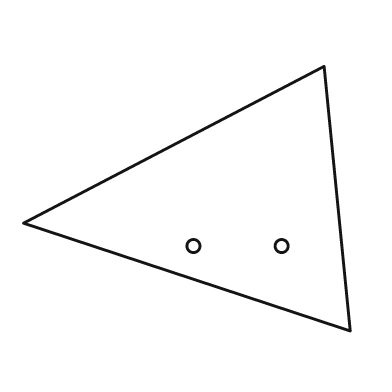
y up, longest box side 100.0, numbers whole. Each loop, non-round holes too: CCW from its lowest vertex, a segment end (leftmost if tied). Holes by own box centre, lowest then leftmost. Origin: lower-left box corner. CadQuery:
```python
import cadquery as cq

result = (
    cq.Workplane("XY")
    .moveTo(100.0, 0.0)
    .lineTo(92.0, 81.0)
    .lineTo(0.0, 33.0)
    .close()
    .moveTo(52.0, 26.0)
    .circle(2.0)
    .moveTo(79.0, 26.0)
    .circle(2.0)
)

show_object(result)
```